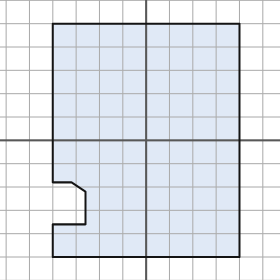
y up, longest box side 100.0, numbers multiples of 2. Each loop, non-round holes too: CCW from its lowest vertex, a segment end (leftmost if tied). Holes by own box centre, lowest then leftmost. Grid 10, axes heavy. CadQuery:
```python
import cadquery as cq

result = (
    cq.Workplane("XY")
    .moveTo(-40.0, -50.0)
    .lineTo(40.0, -50.0)
    .lineTo(40.0, 50.0)
    .lineTo(-40.0, 50.0)
    .lineTo(-40.0, -18.0)
    .lineTo(-32.0, -18.0)
    .lineTo(-26.0, -22.0)
    .lineTo(-26.0, -36.0)
    .lineTo(-40.0, -36.0)
    .close()
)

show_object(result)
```